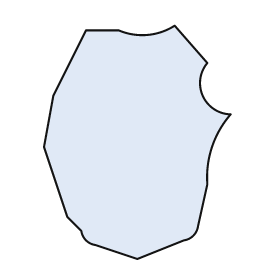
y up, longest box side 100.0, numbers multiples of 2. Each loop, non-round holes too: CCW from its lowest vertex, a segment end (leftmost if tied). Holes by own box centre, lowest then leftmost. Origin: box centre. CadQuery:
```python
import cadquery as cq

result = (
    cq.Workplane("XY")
    .moveTo(0.0, -50.0)
    .lineTo(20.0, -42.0)
    .threePointArc((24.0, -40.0), (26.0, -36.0))
    .lineTo(30.0, -18.0)
    .threePointArc((32.0, -2.0), (40.0, 12.0))
    .threePointArc((28.0, 20.0), (30.0, 34.0))
    .lineTo(16.0, 50.0)
    .threePointArc((4.0, 46.0), (-8.0, 48.0))
    .lineTo(-22.0, 48.0)
    .lineTo(-36.0, 20.0)
    .lineTo(-40.0, -2.0)
    .lineTo(-30.0, -32.0)
    .lineTo(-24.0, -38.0)
    .threePointArc((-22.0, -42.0), (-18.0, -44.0))
    .close()
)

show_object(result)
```